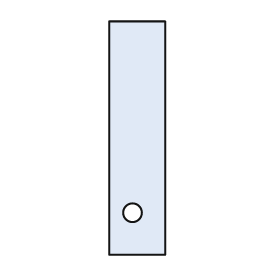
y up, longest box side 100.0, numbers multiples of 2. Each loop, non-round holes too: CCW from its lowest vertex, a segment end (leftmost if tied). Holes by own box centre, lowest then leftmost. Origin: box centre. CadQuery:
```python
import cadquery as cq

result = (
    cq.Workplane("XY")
    .moveTo(-12.0, -50.0)
    .lineTo(12.0, -50.0)
    .lineTo(12.0, 50.0)
    .lineTo(-12.0, 50.0)
    .close()
    .moveTo(-2.0, -32.0)
    .circle(4.0)
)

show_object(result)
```